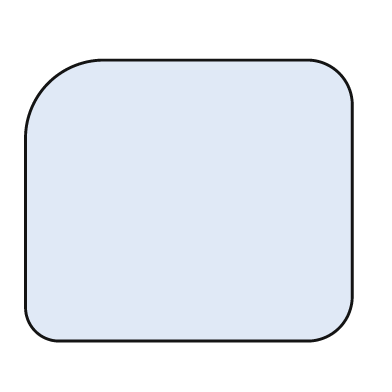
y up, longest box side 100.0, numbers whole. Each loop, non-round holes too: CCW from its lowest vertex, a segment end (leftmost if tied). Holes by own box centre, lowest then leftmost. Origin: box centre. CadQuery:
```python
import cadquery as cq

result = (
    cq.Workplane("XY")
    .moveTo(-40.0, -43.0)
    .lineTo(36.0, -43.0)
    .threePointArc((46.0, -39.0), (50.0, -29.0))
    .lineTo(50.0, 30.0)
    .threePointArc((46.0, 39.0), (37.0, 43.0))
    .lineTo(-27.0, 43.0)
    .threePointArc((-43.0, 36.0), (-50.0, 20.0))
    .lineTo(-50.0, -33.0)
    .threePointArc((-47.0, -40.0), (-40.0, -43.0))
    .close()
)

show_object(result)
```